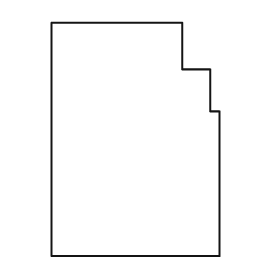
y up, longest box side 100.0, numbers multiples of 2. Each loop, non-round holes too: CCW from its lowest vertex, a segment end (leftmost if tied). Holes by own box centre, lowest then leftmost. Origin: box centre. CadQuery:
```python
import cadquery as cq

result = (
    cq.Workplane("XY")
    .moveTo(-36.0, -50.0)
    .lineTo(36.0, -50.0)
    .lineTo(36.0, 12.0)
    .lineTo(32.0, 12.0)
    .lineTo(32.0, 30.0)
    .lineTo(20.0, 30.0)
    .lineTo(20.0, 50.0)
    .lineTo(-36.0, 50.0)
    .close()
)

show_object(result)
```